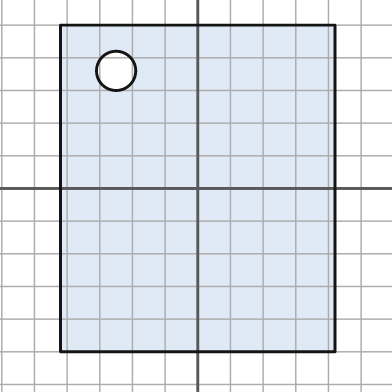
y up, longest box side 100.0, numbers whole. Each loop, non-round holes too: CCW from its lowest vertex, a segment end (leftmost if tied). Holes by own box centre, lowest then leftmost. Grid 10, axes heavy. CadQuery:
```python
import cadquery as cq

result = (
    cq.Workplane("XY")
    .moveTo(-42.0, -50.0)
    .lineTo(42.0, -50.0)
    .lineTo(42.0, 50.0)
    .lineTo(-42.0, 50.0)
    .close()
    .moveTo(-25.0, 36.0)
    .circle(6.0)
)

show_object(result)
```